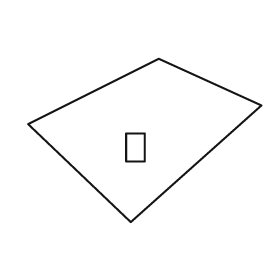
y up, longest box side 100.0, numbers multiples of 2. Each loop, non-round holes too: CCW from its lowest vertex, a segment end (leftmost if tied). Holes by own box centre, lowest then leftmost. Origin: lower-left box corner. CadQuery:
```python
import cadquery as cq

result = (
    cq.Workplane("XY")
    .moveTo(44.0, 0.0)
    .lineTo(100.0, 50.0)
    .lineTo(56.0, 70.0)
    .lineTo(0.0, 42.0)
    .close()
    .moveTo(42.0, 26.0)
    .lineTo(50.0, 26.0)
    .lineTo(50.0, 38.0)
    .lineTo(42.0, 38.0)
    .close()
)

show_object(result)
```